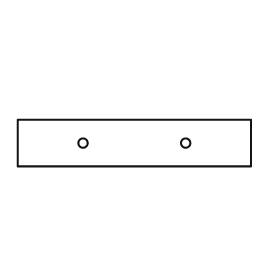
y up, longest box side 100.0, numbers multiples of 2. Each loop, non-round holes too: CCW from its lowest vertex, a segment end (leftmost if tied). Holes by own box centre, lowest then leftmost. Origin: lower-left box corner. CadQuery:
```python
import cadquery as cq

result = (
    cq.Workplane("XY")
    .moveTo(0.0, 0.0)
    .lineTo(100.0, 0.0)
    .lineTo(100.0, 20.0)
    .lineTo(0.0, 20.0)
    .close()
    .moveTo(28.0, 10.0)
    .circle(2.0)
    .moveTo(72.0, 10.0)
    .circle(2.0)
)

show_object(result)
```